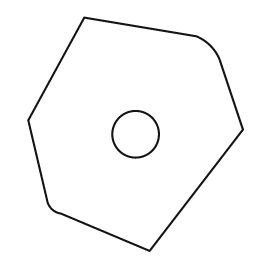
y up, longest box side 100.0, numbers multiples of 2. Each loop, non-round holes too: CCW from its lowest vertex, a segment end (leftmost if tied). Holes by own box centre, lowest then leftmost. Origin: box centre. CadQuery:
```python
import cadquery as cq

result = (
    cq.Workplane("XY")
    .moveTo(6.0, -50.0)
    .lineTo(46.0, 2.0)
    .lineTo(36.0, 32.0)
    .threePointArc((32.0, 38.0), (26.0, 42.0))
    .lineTo(-22.0, 50.0)
    .lineTo(-46.0, 6.0)
    .lineTo(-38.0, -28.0)
    .threePointArc((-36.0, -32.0), (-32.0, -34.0))
    .close()
    .moveTo(0.0, 0.0)
    .circle(10.0)
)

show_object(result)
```